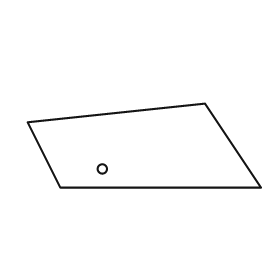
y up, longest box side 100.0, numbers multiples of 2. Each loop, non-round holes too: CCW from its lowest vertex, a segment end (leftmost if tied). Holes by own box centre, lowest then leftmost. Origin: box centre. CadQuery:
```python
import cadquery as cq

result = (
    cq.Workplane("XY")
    .moveTo(-36.0, -18.0)
    .lineTo(50.0, -18.0)
    .lineTo(26.0, 18.0)
    .lineTo(-50.0, 10.0)
    .close()
    .moveTo(-18.0, -10.0)
    .circle(2.0)
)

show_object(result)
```